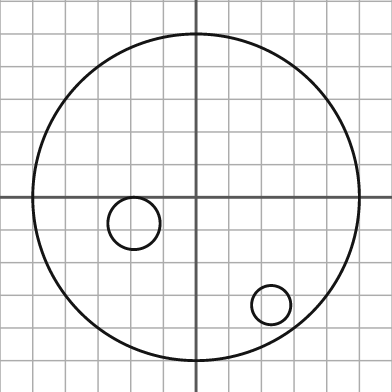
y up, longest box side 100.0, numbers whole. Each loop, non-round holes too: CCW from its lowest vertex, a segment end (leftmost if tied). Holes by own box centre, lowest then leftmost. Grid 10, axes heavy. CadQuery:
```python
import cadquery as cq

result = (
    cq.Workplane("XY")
    .moveTo(0.0, 0.0)
    .circle(50.0)
    .moveTo(23.0, -33.0)
    .circle(6.0)
    .moveTo(-19.0, -8.0)
    .circle(8.0)
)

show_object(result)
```